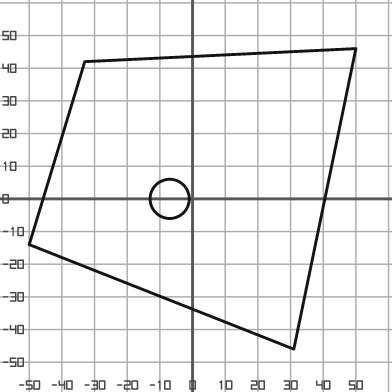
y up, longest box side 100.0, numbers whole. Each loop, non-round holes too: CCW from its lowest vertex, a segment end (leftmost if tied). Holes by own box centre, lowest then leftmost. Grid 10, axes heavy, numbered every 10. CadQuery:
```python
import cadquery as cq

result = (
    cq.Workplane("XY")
    .moveTo(31.0, -46.0)
    .lineTo(50.0, 46.0)
    .lineTo(-33.0, 42.0)
    .lineTo(-50.0, -14.0)
    .close()
    .moveTo(-7.0, 0.0)
    .circle(6.0)
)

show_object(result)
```